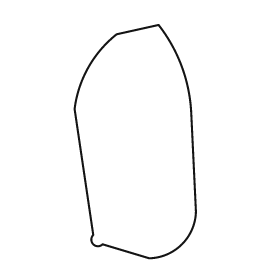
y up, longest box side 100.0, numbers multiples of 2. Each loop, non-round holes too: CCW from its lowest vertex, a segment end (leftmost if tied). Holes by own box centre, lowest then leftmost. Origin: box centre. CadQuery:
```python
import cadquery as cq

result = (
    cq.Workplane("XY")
    .moveTo(6.0, -50.0)
    .threePointArc((20.0, -44.0), (26.0, -30.0))
    .lineTo(24.0, 12.0)
    .threePointArc((20.0, 32.0), (10.0, 50.0))
    .lineTo(-8.0, 46.0)
    .threePointArc((-20.0, 32.0), (-26.0, 14.0))
    .lineTo(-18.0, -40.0)
    .threePointArc((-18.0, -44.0), (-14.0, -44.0))
    .close()
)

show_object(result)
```